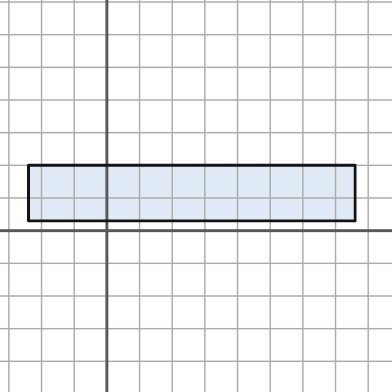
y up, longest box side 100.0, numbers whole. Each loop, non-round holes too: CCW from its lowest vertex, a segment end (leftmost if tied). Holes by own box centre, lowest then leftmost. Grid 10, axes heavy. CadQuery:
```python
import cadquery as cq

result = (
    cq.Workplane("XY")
    .moveTo(-24.0, 3.0)
    .lineTo(76.0, 3.0)
    .lineTo(76.0, 20.0)
    .lineTo(-24.0, 20.0)
    .close()
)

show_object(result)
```